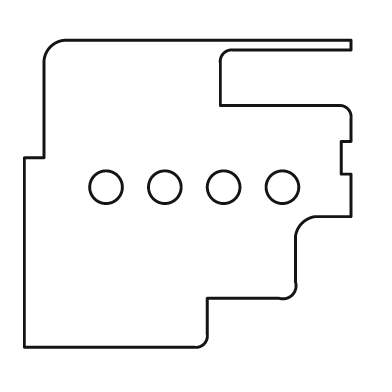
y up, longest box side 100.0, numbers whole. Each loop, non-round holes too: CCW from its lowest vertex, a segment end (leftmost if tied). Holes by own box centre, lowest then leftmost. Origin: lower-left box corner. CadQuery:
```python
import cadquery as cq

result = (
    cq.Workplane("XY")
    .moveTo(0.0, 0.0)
    .lineTo(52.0, 0.0)
    .threePointArc((55.0, 1.0), (56.0, 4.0))
    .lineTo(56.0, 15.0)
    .lineTo(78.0, 15.0)
    .threePointArc((82.0, 16.0), (83.0, 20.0))
    .lineTo(83.0, 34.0)
    .threePointArc((85.0, 38.0), (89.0, 40.0))
    .lineTo(100.0, 40.0)
    .lineTo(100.0, 53.0)
    .lineTo(97.0, 53.0)
    .lineTo(97.0, 63.0)
    .lineTo(100.0, 63.0)
    .lineTo(100.0, 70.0)
    .threePointArc((99.0, 73.0), (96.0, 74.0))
    .lineTo(60.0, 74.0)
    .lineTo(60.0, 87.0)
    .threePointArc((61.0, 90.0), (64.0, 91.0))
    .lineTo(100.0, 91.0)
    .lineTo(100.0, 94.0)
    .lineTo(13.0, 94.0)
    .threePointArc((8.0, 92.0), (6.0, 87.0))
    .lineTo(6.0, 58.0)
    .lineTo(0.0, 58.0)
    .close()
    .moveTo(25.0, 49.0)
    .circle(5.0)
    .moveTo(43.0, 49.0)
    .circle(5.0)
    .moveTo(61.0, 49.0)
    .circle(5.0)
    .moveTo(79.0, 49.0)
    .circle(5.0)
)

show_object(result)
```